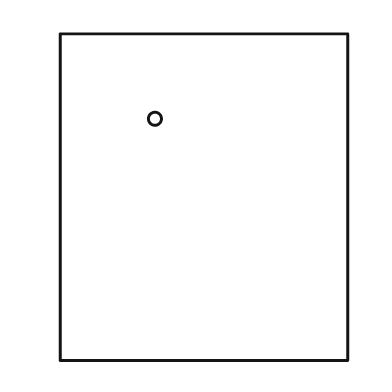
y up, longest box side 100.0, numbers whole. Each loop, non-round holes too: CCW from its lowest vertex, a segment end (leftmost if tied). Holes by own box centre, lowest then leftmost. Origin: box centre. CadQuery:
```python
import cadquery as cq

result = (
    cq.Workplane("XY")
    .moveTo(-44.0, -50.0)
    .lineTo(44.0, -50.0)
    .lineTo(44.0, 50.0)
    .lineTo(-44.0, 50.0)
    .close()
    .moveTo(-15.0, 24.0)
    .circle(2.0)
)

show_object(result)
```